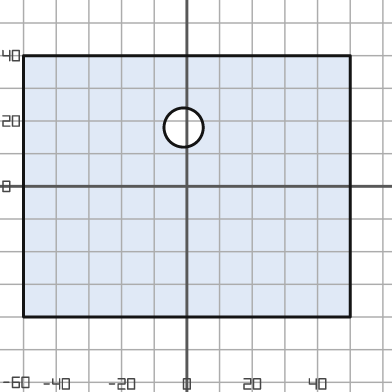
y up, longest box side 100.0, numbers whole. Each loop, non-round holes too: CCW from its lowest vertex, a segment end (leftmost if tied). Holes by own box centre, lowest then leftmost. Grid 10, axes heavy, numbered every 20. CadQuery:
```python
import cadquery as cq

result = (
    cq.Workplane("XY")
    .moveTo(-50.0, -40.0)
    .lineTo(50.0, -40.0)
    .lineTo(50.0, 40.0)
    .lineTo(-50.0, 40.0)
    .close()
    .moveTo(-1.0, 18.0)
    .circle(6.0)
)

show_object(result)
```